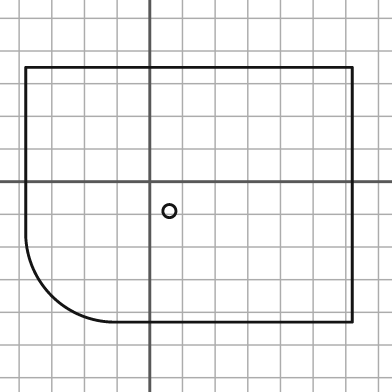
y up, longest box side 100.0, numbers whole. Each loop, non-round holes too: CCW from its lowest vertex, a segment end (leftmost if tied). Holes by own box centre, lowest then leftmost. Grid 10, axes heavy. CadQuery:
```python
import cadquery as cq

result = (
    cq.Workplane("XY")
    .moveTo(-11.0, -43.0)
    .lineTo(62.0, -43.0)
    .lineTo(62.0, 35.0)
    .lineTo(-38.0, 35.0)
    .lineTo(-38.0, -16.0)
    .threePointArc((-30.0, -35.0), (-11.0, -43.0))
    .close()
    .moveTo(6.0, -9.0)
    .circle(2.0)
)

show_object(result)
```